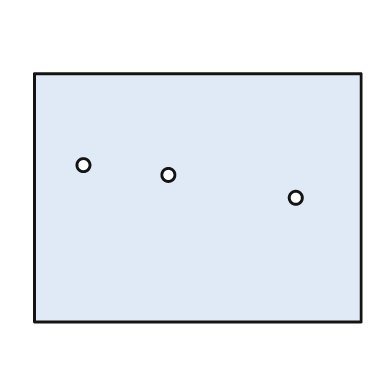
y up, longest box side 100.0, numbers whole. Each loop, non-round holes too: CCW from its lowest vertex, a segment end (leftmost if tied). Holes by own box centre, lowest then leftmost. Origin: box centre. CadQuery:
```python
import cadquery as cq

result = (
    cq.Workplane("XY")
    .moveTo(-50.0, -38.0)
    .lineTo(50.0, -38.0)
    .lineTo(50.0, 38.0)
    .lineTo(-50.0, 38.0)
    .close()
    .moveTo(30.0, 0.0)
    .circle(2.0)
    .moveTo(-9.0, 7.0)
    .circle(2.0)
    .moveTo(-35.0, 10.0)
    .circle(2.0)
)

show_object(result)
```